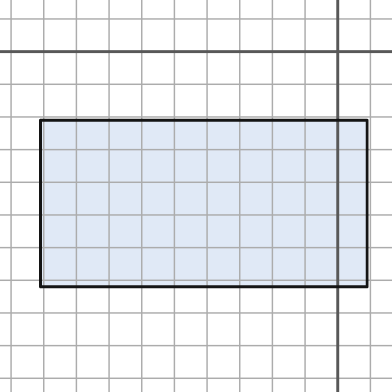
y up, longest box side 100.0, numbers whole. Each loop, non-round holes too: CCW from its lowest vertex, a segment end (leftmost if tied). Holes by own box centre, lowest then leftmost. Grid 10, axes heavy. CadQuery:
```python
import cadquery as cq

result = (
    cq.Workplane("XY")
    .moveTo(-91.0, -72.0)
    .lineTo(9.0, -72.0)
    .lineTo(9.0, -21.0)
    .lineTo(-91.0, -21.0)
    .close()
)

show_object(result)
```